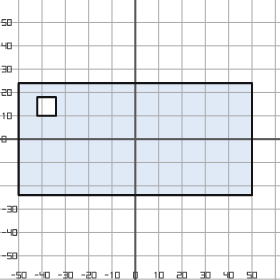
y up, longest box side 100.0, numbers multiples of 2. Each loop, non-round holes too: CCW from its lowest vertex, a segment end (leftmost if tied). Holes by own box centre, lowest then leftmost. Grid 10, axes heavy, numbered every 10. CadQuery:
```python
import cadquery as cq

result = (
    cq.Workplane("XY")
    .moveTo(-50.0, -24.0)
    .lineTo(50.0, -24.0)
    .lineTo(50.0, 24.0)
    .lineTo(-50.0, 24.0)
    .close()
    .moveTo(-42.0, 10.0)
    .lineTo(-34.0, 10.0)
    .lineTo(-34.0, 18.0)
    .lineTo(-42.0, 18.0)
    .close()
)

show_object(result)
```